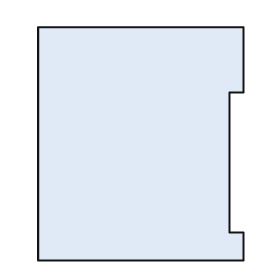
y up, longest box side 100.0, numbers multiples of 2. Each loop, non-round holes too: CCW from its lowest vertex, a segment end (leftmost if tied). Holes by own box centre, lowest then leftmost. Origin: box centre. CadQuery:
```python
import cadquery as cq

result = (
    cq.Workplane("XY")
    .moveTo(-44.0, -50.0)
    .lineTo(44.0, -50.0)
    .lineTo(44.0, -38.0)
    .lineTo(38.0, -38.0)
    .lineTo(38.0, 22.0)
    .lineTo(44.0, 22.0)
    .lineTo(44.0, 50.0)
    .lineTo(-44.0, 50.0)
    .close()
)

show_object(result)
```